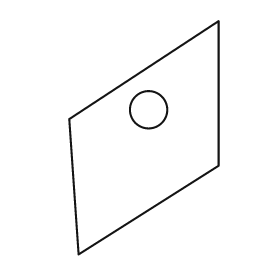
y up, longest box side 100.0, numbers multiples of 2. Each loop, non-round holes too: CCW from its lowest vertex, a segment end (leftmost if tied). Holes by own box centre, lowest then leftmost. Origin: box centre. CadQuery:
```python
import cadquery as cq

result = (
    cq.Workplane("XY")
    .moveTo(-28.0, -50.0)
    .lineTo(32.0, -12.0)
    .lineTo(32.0, 50.0)
    .lineTo(-32.0, 8.0)
    .close()
    .moveTo(2.0, 12.0)
    .circle(8.0)
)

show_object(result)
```